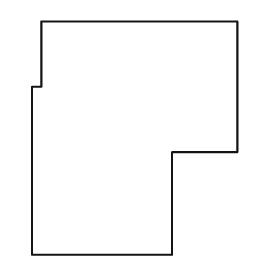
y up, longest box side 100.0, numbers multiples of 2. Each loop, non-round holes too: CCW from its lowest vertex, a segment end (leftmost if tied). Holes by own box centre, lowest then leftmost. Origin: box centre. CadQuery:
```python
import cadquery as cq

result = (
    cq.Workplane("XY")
    .moveTo(-44.0, -50.0)
    .lineTo(16.0, -50.0)
    .lineTo(16.0, -6.0)
    .lineTo(44.0, -6.0)
    .lineTo(44.0, 50.0)
    .lineTo(-40.0, 50.0)
    .lineTo(-40.0, 22.0)
    .lineTo(-44.0, 22.0)
    .close()
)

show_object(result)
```